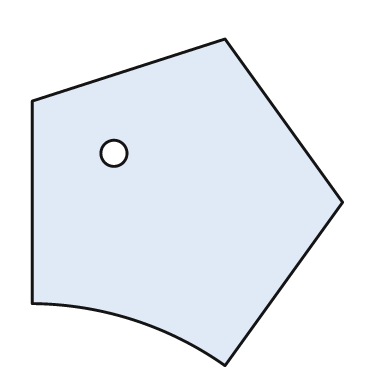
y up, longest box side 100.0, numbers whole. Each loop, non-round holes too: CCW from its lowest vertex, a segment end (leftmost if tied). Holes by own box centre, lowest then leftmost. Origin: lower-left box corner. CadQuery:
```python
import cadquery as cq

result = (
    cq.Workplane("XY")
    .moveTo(59.0, 0.0)
    .lineTo(95.0, 50.0)
    .lineTo(59.0, 100.0)
    .lineTo(0.0, 81.0)
    .lineTo(0.0, 19.0)
    .threePointArc((31.0, 14.0), (59.0, 0.0))
    .close()
    .moveTo(25.0, 65.0)
    .circle(4.0)
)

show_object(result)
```